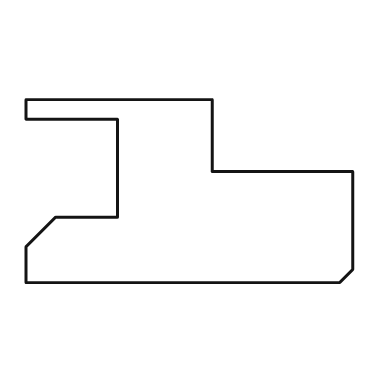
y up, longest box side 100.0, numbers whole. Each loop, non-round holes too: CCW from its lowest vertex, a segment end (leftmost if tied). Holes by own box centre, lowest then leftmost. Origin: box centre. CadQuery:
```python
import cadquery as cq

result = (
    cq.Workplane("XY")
    .moveTo(-50.0, -28.0)
    .lineTo(46.0, -28.0)
    .lineTo(50.0, -24.0)
    .lineTo(50.0, 6.0)
    .lineTo(7.0, 6.0)
    .lineTo(7.0, 28.0)
    .lineTo(-50.0, 28.0)
    .lineTo(-50.0, 22.0)
    .lineTo(-22.0, 22.0)
    .lineTo(-22.0, -8.0)
    .lineTo(-41.0, -8.0)
    .lineTo(-50.0, -17.0)
    .close()
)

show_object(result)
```